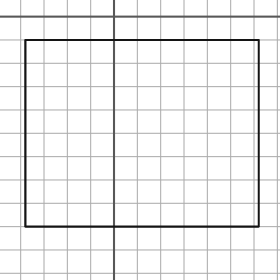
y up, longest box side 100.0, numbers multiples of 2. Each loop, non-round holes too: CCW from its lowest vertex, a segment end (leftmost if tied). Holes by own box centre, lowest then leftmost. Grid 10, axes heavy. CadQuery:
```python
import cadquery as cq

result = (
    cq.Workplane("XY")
    .moveTo(-38.0, -90.0)
    .lineTo(62.0, -90.0)
    .lineTo(62.0, -10.0)
    .lineTo(-38.0, -10.0)
    .close()
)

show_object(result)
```